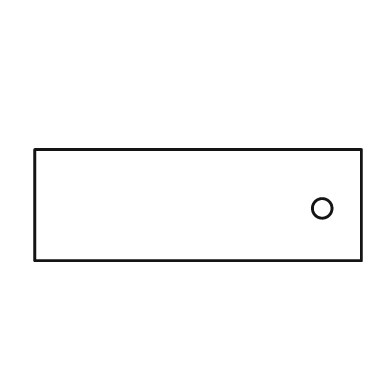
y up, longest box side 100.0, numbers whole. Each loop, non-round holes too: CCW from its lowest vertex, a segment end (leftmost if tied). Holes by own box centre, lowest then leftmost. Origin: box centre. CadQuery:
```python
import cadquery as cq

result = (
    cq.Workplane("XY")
    .moveTo(-50.0, -17.0)
    .lineTo(50.0, -17.0)
    .lineTo(50.0, 17.0)
    .lineTo(-50.0, 17.0)
    .close()
    .moveTo(38.0, -1.0)
    .circle(3.0)
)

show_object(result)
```